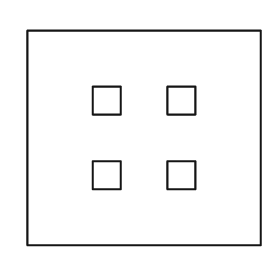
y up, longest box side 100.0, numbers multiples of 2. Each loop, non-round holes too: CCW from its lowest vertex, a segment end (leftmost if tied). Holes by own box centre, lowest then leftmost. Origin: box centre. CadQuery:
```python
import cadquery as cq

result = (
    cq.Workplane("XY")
    .moveTo(-50.0, -46.0)
    .lineTo(50.0, -46.0)
    .lineTo(50.0, 46.0)
    .lineTo(-50.0, 46.0)
    .close()
    .moveTo(-22.0, -22.0)
    .lineTo(-10.0, -22.0)
    .lineTo(-10.0, -10.0)
    .lineTo(-22.0, -10.0)
    .close()
    .moveTo(10.0, -22.0)
    .lineTo(22.0, -22.0)
    .lineTo(22.0, -10.0)
    .lineTo(10.0, -10.0)
    .close()
    .moveTo(-22.0, 10.0)
    .lineTo(-10.0, 10.0)
    .lineTo(-10.0, 22.0)
    .lineTo(-22.0, 22.0)
    .close()
    .moveTo(10.0, 10.0)
    .lineTo(22.0, 10.0)
    .lineTo(22.0, 22.0)
    .lineTo(10.0, 22.0)
    .close()
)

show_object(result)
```